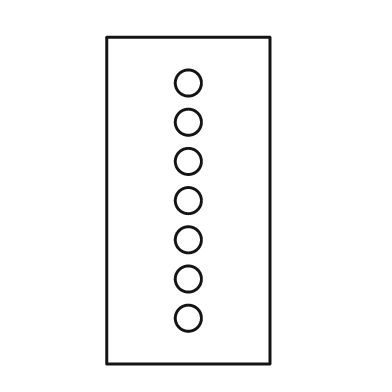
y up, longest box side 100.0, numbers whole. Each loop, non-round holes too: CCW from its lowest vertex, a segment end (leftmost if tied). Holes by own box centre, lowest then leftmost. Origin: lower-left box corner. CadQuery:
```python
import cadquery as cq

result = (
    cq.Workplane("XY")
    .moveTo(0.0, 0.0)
    .lineTo(50.0, 0.0)
    .lineTo(50.0, 100.0)
    .lineTo(0.0, 100.0)
    .close()
    .moveTo(25.0, 14.0)
    .circle(4.0)
    .moveTo(25.0, 26.0)
    .circle(4.0)
    .moveTo(25.0, 38.0)
    .circle(4.0)
    .moveTo(25.0, 50.0)
    .circle(4.0)
    .moveTo(25.0, 62.0)
    .circle(4.0)
    .moveTo(25.0, 74.0)
    .circle(4.0)
    .moveTo(25.0, 86.0)
    .circle(4.0)
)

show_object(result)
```